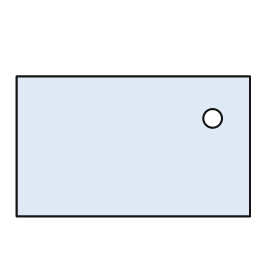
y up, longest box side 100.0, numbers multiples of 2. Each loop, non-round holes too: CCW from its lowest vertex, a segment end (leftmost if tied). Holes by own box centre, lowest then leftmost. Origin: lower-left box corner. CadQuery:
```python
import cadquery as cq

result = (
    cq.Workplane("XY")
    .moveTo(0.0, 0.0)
    .lineTo(100.0, 0.0)
    .lineTo(100.0, 60.0)
    .lineTo(0.0, 60.0)
    .close()
    .moveTo(84.0, 42.0)
    .circle(4.0)
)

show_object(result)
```